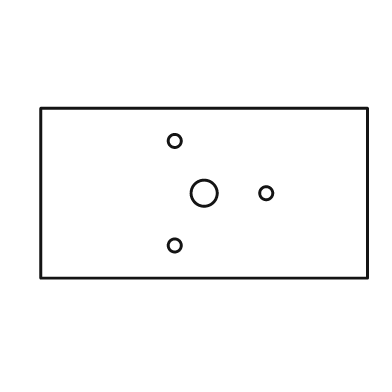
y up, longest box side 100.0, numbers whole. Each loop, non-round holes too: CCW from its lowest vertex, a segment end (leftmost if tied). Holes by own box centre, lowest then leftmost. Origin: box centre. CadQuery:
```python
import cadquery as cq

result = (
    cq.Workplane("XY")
    .moveTo(-50.0, -26.0)
    .lineTo(50.0, -26.0)
    .lineTo(50.0, 26.0)
    .lineTo(-50.0, 26.0)
    .close()
    .moveTo(-9.0, -16.0)
    .circle(2.0)
    .moveTo(0.0, 0.0)
    .circle(4.0)
    .moveTo(19.0, 0.0)
    .circle(2.0)
    .moveTo(-9.0, 16.0)
    .circle(2.0)
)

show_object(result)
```